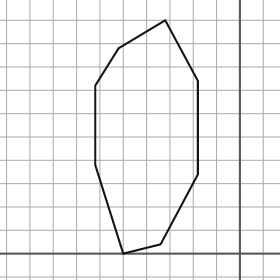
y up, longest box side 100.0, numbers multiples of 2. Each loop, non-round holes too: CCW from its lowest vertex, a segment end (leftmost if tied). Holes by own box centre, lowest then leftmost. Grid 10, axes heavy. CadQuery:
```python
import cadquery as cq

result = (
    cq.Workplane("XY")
    .moveTo(-50.0, 0.0)
    .lineTo(-34.0, 4.0)
    .lineTo(-18.0, 34.0)
    .lineTo(-18.0, 74.0)
    .lineTo(-32.0, 100.0)
    .lineTo(-52.0, 88.0)
    .lineTo(-62.0, 72.0)
    .lineTo(-62.0, 38.0)
    .close()
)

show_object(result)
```